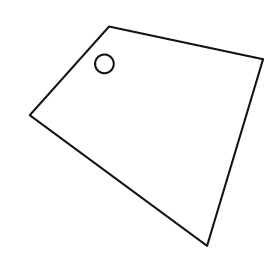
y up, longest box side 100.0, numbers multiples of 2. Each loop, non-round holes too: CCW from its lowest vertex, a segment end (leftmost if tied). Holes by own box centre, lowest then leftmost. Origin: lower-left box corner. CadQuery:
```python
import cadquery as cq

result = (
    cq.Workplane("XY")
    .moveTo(76.0, 0.0)
    .lineTo(100.0, 80.0)
    .lineTo(34.0, 94.0)
    .lineTo(0.0, 56.0)
    .close()
    .moveTo(32.0, 78.0)
    .circle(4.0)
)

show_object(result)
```